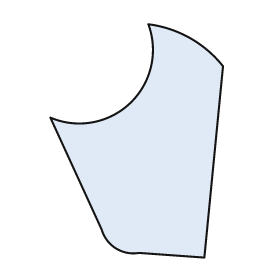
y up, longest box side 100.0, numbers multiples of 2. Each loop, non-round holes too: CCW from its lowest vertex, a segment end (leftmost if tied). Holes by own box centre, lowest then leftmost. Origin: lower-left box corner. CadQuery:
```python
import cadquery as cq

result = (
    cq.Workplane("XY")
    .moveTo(66.0, 0.0)
    .lineTo(74.0, 82.0)
    .threePointArc((60.0, 94.0), (42.0, 100.0))
    .threePointArc((34.0, 66.0), (0.0, 60.0))
    .lineTo(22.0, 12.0)
    .threePointArc((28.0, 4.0), (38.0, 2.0))
    .close()
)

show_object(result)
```